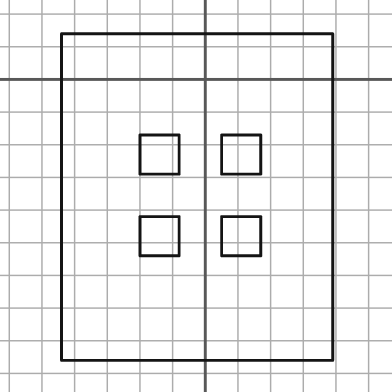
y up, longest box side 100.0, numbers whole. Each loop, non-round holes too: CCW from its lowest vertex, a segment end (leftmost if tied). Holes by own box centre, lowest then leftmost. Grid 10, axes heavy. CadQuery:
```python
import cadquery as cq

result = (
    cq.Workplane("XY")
    .moveTo(-44.0, -86.0)
    .lineTo(39.0, -86.0)
    .lineTo(39.0, 14.0)
    .lineTo(-44.0, 14.0)
    .close()
    .moveTo(-20.0, -54.0)
    .lineTo(-8.0, -54.0)
    .lineTo(-8.0, -42.0)
    .lineTo(-20.0, -42.0)
    .close()
    .moveTo(5.0, -54.0)
    .lineTo(17.0, -54.0)
    .lineTo(17.0, -42.0)
    .lineTo(5.0, -42.0)
    .close()
    .moveTo(-20.0, -29.0)
    .lineTo(-8.0, -29.0)
    .lineTo(-8.0, -17.0)
    .lineTo(-20.0, -17.0)
    .close()
    .moveTo(5.0, -29.0)
    .lineTo(17.0, -29.0)
    .lineTo(17.0, -17.0)
    .lineTo(5.0, -17.0)
    .close()
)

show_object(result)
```